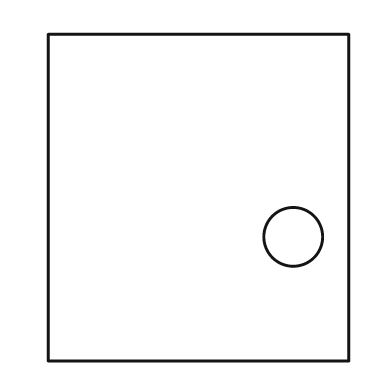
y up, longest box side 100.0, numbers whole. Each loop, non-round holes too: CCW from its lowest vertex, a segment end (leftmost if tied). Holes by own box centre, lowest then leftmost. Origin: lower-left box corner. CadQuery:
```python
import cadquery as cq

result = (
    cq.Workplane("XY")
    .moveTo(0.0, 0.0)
    .lineTo(92.0, 0.0)
    .lineTo(92.0, 100.0)
    .lineTo(0.0, 100.0)
    .close()
    .moveTo(75.0, 38.0)
    .circle(9.0)
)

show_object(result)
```